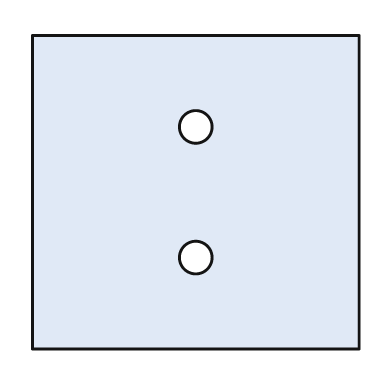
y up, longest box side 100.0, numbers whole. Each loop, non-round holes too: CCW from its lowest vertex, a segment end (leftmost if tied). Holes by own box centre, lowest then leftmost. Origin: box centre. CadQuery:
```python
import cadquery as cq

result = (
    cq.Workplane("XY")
    .moveTo(-50.0, -48.0)
    .lineTo(50.0, -48.0)
    .lineTo(50.0, 48.0)
    .lineTo(-50.0, 48.0)
    .close()
    .moveTo(0.0, -20.0)
    .circle(5.0)
    .moveTo(0.0, 20.0)
    .circle(5.0)
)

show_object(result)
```